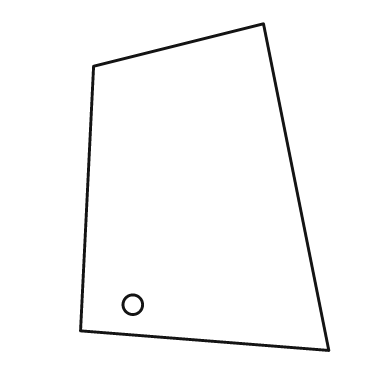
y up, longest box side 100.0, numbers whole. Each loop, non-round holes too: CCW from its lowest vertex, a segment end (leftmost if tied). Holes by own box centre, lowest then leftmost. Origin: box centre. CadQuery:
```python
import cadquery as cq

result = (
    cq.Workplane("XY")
    .moveTo(38.0, -50.0)
    .lineTo(18.0, 50.0)
    .lineTo(-34.0, 37.0)
    .lineTo(-38.0, -44.0)
    .close()
    .moveTo(-22.0, -36.0)
    .circle(3.0)
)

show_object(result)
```